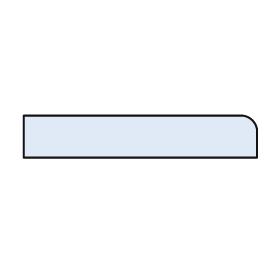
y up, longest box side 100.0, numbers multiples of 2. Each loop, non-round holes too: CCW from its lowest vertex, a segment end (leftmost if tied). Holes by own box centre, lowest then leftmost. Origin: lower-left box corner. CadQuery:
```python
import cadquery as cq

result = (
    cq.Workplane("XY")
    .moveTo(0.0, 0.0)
    .lineTo(100.0, 0.0)
    .lineTo(100.0, 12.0)
    .threePointArc((98.0, 16.0), (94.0, 18.0))
    .lineTo(0.0, 18.0)
    .close()
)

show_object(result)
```